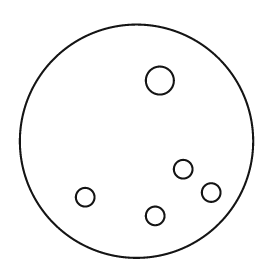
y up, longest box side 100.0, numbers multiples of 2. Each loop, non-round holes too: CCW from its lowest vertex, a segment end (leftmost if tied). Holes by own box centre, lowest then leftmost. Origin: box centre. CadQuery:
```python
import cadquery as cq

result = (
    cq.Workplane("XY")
    .moveTo(0.0, 0.0)
    .circle(50.0)
    .moveTo(8.0, -32.0)
    .circle(4.0)
    .moveTo(-22.0, -24.0)
    .circle(4.0)
    .moveTo(32.0, -22.0)
    .circle(4.0)
    .moveTo(20.0, -12.0)
    .circle(4.0)
    .moveTo(10.0, 26.0)
    .circle(6.0)
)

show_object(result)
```